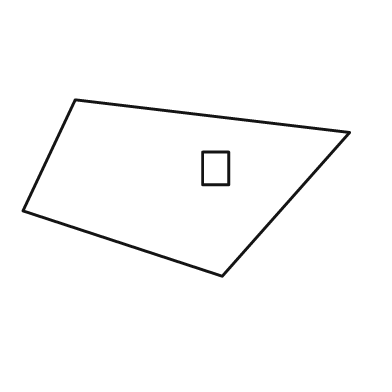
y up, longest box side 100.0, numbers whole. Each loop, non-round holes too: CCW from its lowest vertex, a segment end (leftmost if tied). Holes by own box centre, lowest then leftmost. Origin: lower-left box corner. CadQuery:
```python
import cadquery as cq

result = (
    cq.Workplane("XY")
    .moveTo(61.0, 0.0)
    .lineTo(100.0, 44.0)
    .lineTo(16.0, 54.0)
    .lineTo(0.0, 20.0)
    .close()
    .moveTo(55.0, 28.0)
    .lineTo(63.0, 28.0)
    .lineTo(63.0, 38.0)
    .lineTo(55.0, 38.0)
    .close()
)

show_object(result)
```